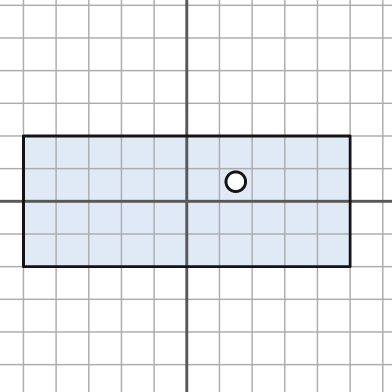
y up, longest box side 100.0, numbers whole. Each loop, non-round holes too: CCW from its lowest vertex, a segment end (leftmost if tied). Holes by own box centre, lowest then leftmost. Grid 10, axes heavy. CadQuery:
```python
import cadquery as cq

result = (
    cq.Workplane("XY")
    .moveTo(-50.0, -20.0)
    .lineTo(50.0, -20.0)
    .lineTo(50.0, 20.0)
    .lineTo(-50.0, 20.0)
    .close()
    .moveTo(15.0, 6.0)
    .circle(3.0)
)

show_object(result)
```